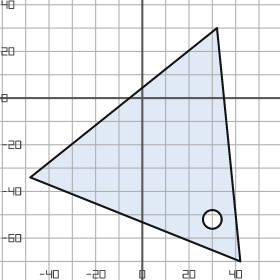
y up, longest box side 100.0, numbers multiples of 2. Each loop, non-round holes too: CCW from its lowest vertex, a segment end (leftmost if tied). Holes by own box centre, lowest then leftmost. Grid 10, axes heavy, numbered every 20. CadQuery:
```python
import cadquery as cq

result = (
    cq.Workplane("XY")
    .moveTo(42.0, -70.0)
    .lineTo(32.0, 30.0)
    .lineTo(-48.0, -34.0)
    .close()
    .moveTo(30.0, -52.0)
    .circle(4.0)
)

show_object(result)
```